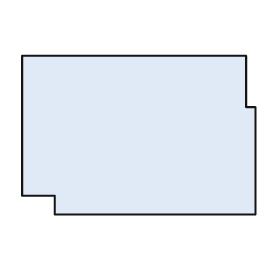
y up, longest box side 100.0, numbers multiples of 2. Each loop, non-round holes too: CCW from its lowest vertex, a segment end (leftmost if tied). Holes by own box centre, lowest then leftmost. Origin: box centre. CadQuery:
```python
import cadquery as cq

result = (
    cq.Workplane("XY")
    .moveTo(-36.0, -34.0)
    .lineTo(50.0, -34.0)
    .lineTo(50.0, 12.0)
    .lineTo(46.0, 12.0)
    .lineTo(46.0, 34.0)
    .lineTo(-50.0, 34.0)
    .lineTo(-50.0, -26.0)
    .lineTo(-36.0, -26.0)
    .close()
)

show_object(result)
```